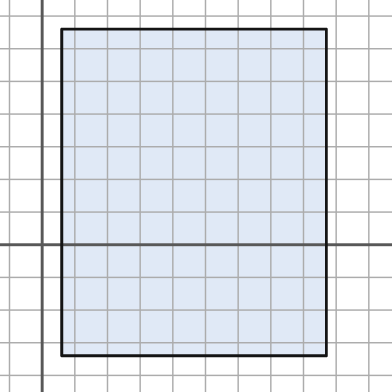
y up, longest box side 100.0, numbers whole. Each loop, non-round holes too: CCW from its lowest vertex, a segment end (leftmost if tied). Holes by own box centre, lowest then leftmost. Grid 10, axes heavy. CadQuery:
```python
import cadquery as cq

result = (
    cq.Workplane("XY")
    .moveTo(6.0, -34.0)
    .lineTo(87.0, -34.0)
    .lineTo(87.0, 66.0)
    .lineTo(6.0, 66.0)
    .close()
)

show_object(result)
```